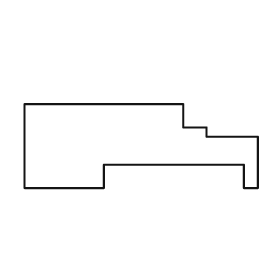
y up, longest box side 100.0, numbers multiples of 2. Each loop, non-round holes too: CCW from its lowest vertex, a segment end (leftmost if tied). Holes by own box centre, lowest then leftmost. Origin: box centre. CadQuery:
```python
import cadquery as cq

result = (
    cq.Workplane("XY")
    .moveTo(-50.0, -18.0)
    .lineTo(-16.0, -18.0)
    .lineTo(-16.0, -8.0)
    .lineTo(44.0, -8.0)
    .lineTo(44.0, -18.0)
    .lineTo(50.0, -18.0)
    .lineTo(50.0, 4.0)
    .lineTo(28.0, 4.0)
    .lineTo(28.0, 8.0)
    .lineTo(18.0, 8.0)
    .lineTo(18.0, 18.0)
    .lineTo(-50.0, 18.0)
    .close()
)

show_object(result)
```